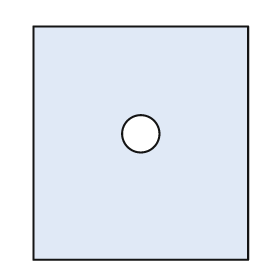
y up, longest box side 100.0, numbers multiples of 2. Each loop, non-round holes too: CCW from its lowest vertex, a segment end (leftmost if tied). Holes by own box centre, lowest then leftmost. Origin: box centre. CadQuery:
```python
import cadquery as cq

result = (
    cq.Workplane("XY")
    .moveTo(-46.0, -50.0)
    .lineTo(46.0, -50.0)
    .lineTo(46.0, 50.0)
    .lineTo(-46.0, 50.0)
    .close()
    .moveTo(0.0, 4.0)
    .circle(8.0)
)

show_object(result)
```